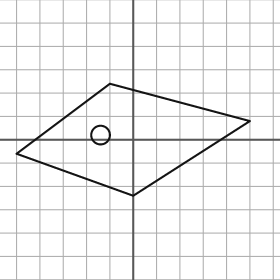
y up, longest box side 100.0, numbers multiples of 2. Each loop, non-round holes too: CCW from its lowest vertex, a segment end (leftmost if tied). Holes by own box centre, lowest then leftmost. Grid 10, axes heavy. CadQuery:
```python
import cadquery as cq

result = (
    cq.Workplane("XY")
    .moveTo(0.0, -24.0)
    .lineTo(50.0, 8.0)
    .lineTo(-10.0, 24.0)
    .lineTo(-50.0, -6.0)
    .close()
    .moveTo(-14.0, 2.0)
    .circle(4.0)
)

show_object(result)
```